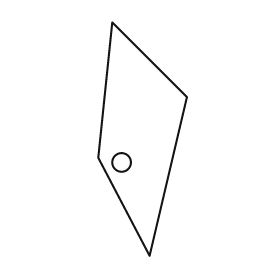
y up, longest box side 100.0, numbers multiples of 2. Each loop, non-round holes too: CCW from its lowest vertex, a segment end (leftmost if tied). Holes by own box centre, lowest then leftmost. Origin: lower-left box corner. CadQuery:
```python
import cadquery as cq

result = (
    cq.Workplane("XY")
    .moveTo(22.0, 0.0)
    .lineTo(38.0, 68.0)
    .lineTo(6.0, 100.0)
    .lineTo(0.0, 42.0)
    .close()
    .moveTo(10.0, 40.0)
    .circle(4.0)
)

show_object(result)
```